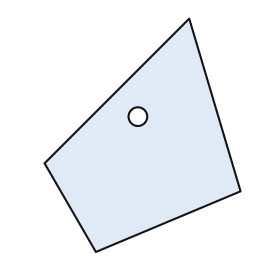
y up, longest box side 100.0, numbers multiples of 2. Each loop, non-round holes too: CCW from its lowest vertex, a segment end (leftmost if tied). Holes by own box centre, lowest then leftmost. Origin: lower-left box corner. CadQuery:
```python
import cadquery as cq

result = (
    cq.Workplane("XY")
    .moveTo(22.0, 0.0)
    .lineTo(84.0, 26.0)
    .lineTo(62.0, 100.0)
    .lineTo(0.0, 38.0)
    .close()
    .moveTo(40.0, 58.0)
    .circle(4.0)
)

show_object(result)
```